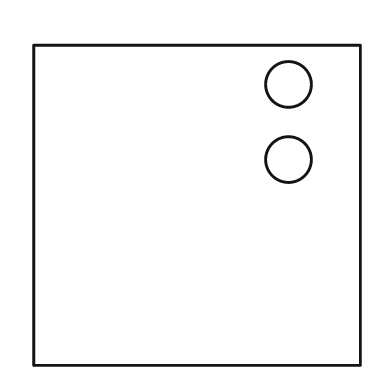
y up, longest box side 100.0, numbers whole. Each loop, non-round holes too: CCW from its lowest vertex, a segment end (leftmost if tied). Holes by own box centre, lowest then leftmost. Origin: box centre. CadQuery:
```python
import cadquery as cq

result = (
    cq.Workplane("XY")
    .moveTo(-50.0, -49.0)
    .lineTo(50.0, -49.0)
    .lineTo(50.0, 49.0)
    .lineTo(-50.0, 49.0)
    .close()
    .moveTo(28.0, 14.0)
    .circle(7.0)
    .moveTo(28.0, 37.0)
    .circle(7.0)
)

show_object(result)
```